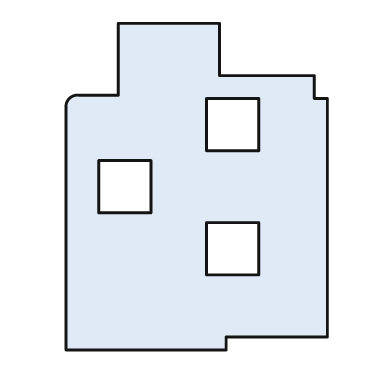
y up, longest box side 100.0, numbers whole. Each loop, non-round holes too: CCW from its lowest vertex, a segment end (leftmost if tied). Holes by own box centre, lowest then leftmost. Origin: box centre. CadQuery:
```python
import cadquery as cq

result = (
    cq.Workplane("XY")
    .moveTo(-40.0, -50.0)
    .lineTo(9.0, -50.0)
    .lineTo(9.0, -46.0)
    .lineTo(40.0, -46.0)
    .lineTo(40.0, 27.0)
    .lineTo(36.0, 27.0)
    .lineTo(36.0, 34.0)
    .lineTo(7.0, 34.0)
    .lineTo(7.0, 50.0)
    .lineTo(-24.0, 50.0)
    .lineTo(-24.0, 28.0)
    .lineTo(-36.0, 28.0)
    .threePointArc((-39.0, 27.0), (-40.0, 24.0))
    .close()
    .moveTo(3.0, -27.0)
    .lineTo(19.0, -27.0)
    .lineTo(19.0, -11.0)
    .lineTo(3.0, -11.0)
    .close()
    .moveTo(-30.0, -8.0)
    .lineTo(-14.0, -8.0)
    .lineTo(-14.0, 8.0)
    .lineTo(-30.0, 8.0)
    .close()
    .moveTo(3.0, 11.0)
    .lineTo(19.0, 11.0)
    .lineTo(19.0, 27.0)
    .lineTo(3.0, 27.0)
    .close()
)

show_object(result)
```